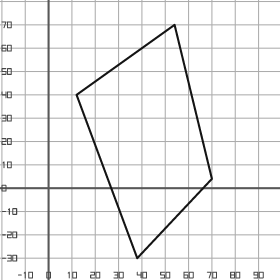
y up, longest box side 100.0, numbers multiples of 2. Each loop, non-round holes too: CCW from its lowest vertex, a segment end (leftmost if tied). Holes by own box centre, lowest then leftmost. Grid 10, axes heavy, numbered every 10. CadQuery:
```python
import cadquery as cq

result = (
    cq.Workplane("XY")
    .moveTo(38.0, -30.0)
    .lineTo(70.0, 4.0)
    .lineTo(54.0, 70.0)
    .lineTo(12.0, 40.0)
    .close()
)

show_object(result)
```